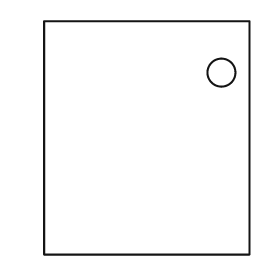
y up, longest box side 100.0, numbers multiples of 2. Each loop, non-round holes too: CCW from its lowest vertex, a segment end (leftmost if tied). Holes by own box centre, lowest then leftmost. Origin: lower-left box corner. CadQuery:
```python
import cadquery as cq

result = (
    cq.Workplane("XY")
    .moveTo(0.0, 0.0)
    .lineTo(88.0, 0.0)
    .lineTo(88.0, 100.0)
    .lineTo(0.0, 100.0)
    .close()
    .moveTo(76.0, 78.0)
    .circle(6.0)
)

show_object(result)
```